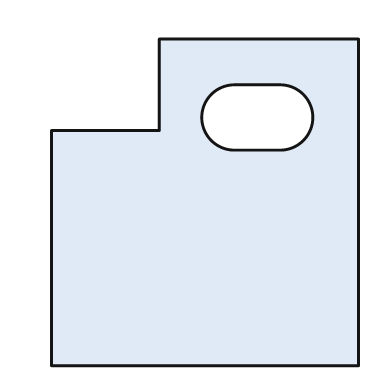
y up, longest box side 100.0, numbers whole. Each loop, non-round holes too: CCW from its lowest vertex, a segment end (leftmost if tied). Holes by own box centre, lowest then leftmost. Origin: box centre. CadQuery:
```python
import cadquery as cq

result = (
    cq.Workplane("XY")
    .moveTo(-47.0, -50.0)
    .lineTo(47.0, -50.0)
    .lineTo(47.0, 50.0)
    .lineTo(-14.0, 50.0)
    .lineTo(-14.0, 22.0)
    .lineTo(-47.0, 22.0)
    .close()
    .moveTo(9.0, 16.0)
    .lineTo(23.0, 16.0)
    .threePointArc((33.0, 26.0), (23.0, 36.0))
    .lineTo(9.0, 36.0)
    .threePointArc((-1.0, 26.0), (9.0, 16.0))
    .close()
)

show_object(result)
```